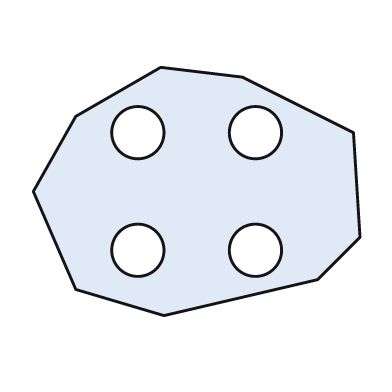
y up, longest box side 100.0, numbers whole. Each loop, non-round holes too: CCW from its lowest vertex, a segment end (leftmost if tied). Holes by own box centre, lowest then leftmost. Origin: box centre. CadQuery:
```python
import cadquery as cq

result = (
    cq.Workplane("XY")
    .moveTo(-10.0, -38.0)
    .lineTo(37.0, -27.0)
    .lineTo(50.0, -14.0)
    .lineTo(48.0, 18.0)
    .lineTo(14.0, 35.0)
    .lineTo(-11.0, 38.0)
    .lineTo(-37.0, 23.0)
    .lineTo(-50.0, 0.0)
    .lineTo(-37.0, -30.0)
    .close()
    .moveTo(-18.0, -18.0)
    .circle(8.0)
    .moveTo(18.0, -18.0)
    .circle(8.0)
    .moveTo(-18.0, 18.0)
    .circle(8.0)
    .moveTo(18.0, 18.0)
    .circle(8.0)
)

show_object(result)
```